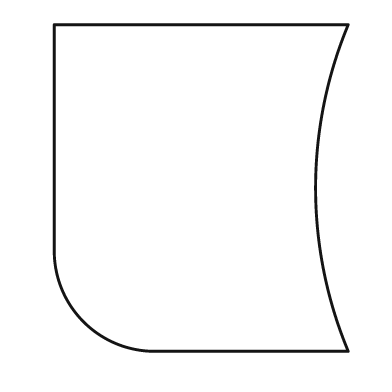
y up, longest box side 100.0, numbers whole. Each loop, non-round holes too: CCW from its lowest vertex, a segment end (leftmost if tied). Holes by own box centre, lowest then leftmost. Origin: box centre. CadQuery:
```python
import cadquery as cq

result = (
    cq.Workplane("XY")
    .moveTo(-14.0, -50.0)
    .lineTo(45.0, -50.0)
    .threePointArc((35.0, 0.0), (45.0, 50.0))
    .lineTo(-45.0, 50.0)
    .lineTo(-45.0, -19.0)
    .threePointArc((-36.0, -41.0), (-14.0, -50.0))
    .close()
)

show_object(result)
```